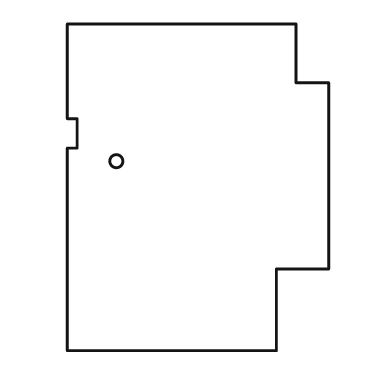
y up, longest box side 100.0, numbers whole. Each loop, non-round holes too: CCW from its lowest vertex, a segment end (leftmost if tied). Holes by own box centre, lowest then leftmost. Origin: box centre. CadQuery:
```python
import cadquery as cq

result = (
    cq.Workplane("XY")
    .moveTo(-40.0, -50.0)
    .lineTo(24.0, -50.0)
    .lineTo(24.0, -25.0)
    .lineTo(40.0, -25.0)
    .lineTo(40.0, 32.0)
    .lineTo(30.0, 32.0)
    .lineTo(30.0, 50.0)
    .lineTo(-40.0, 50.0)
    .lineTo(-40.0, 21.0)
    .lineTo(-37.0, 21.0)
    .lineTo(-37.0, 12.0)
    .lineTo(-40.0, 12.0)
    .close()
    .moveTo(-25.0, 8.0)
    .circle(2.0)
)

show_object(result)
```